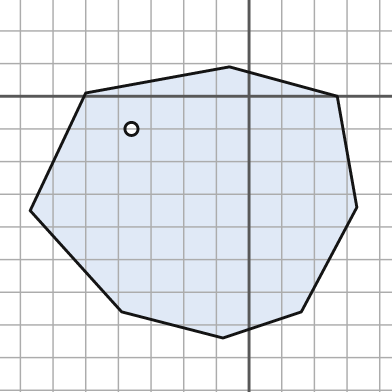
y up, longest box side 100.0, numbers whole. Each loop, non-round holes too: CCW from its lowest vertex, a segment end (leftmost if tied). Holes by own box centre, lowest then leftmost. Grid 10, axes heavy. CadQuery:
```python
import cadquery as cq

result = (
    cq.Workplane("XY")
    .moveTo(-8.0, -74.0)
    .lineTo(16.0, -66.0)
    .lineTo(33.0, -34.0)
    .lineTo(27.0, 0.0)
    .lineTo(-6.0, 9.0)
    .lineTo(-50.0, 1.0)
    .lineTo(-67.0, -35.0)
    .lineTo(-39.0, -66.0)
    .close()
    .moveTo(-36.0, -10.0)
    .circle(2.0)
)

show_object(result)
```